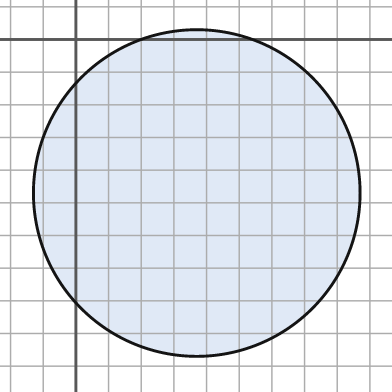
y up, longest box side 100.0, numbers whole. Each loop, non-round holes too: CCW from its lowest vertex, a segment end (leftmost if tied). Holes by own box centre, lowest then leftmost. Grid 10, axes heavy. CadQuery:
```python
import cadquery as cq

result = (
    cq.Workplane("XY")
    .moveTo(37.0, -47.0)
    .circle(50.0)
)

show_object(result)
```